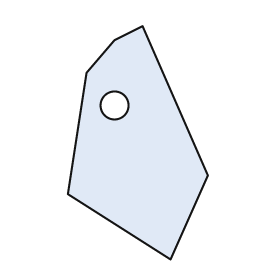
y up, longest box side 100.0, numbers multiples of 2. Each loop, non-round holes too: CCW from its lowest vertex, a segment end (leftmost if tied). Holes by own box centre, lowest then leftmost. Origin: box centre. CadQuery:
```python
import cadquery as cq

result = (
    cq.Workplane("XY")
    .moveTo(14.0, -50.0)
    .lineTo(30.0, -14.0)
    .lineTo(2.0, 50.0)
    .lineTo(-10.0, 44.0)
    .lineTo(-22.0, 30.0)
    .lineTo(-30.0, -22.0)
    .close()
    .moveTo(-10.0, 16.0)
    .circle(6.0)
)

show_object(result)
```